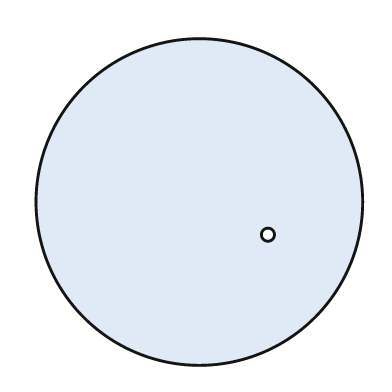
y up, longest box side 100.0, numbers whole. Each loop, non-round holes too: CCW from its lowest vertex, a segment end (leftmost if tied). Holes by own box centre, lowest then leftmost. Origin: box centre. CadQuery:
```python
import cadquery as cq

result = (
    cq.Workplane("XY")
    .moveTo(0.0, 0.0)
    .circle(50.0)
    .moveTo(21.0, -10.0)
    .circle(2.0)
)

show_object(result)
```